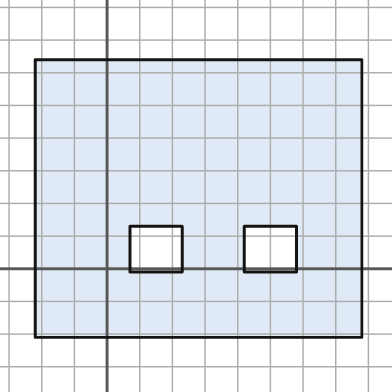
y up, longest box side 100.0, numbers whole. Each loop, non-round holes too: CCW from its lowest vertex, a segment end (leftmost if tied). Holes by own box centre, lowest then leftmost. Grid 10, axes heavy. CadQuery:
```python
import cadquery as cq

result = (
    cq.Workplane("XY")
    .moveTo(-22.0, -21.0)
    .lineTo(78.0, -21.0)
    .lineTo(78.0, 64.0)
    .lineTo(-22.0, 64.0)
    .close()
    .moveTo(7.0, -1.0)
    .lineTo(23.0, -1.0)
    .lineTo(23.0, 13.0)
    .lineTo(7.0, 13.0)
    .close()
    .moveTo(42.0, -1.0)
    .lineTo(58.0, -1.0)
    .lineTo(58.0, 13.0)
    .lineTo(42.0, 13.0)
    .close()
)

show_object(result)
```